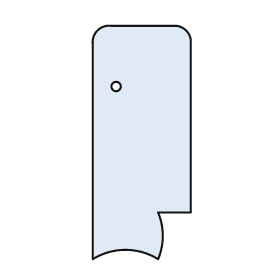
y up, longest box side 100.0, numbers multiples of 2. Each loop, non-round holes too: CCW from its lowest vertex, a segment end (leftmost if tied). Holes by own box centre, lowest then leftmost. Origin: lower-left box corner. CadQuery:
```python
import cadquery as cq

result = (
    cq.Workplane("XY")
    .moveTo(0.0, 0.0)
    .threePointArc((14.0, 4.0), (28.0, 0.0))
    .threePointArc((30.0, 10.0), (28.0, 20.0))
    .lineTo(42.0, 20.0)
    .lineTo(42.0, 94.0)
    .threePointArc((40.0, 98.0), (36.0, 100.0))
    .lineTo(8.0, 100.0)
    .threePointArc((2.0, 98.0), (0.0, 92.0))
    .close()
    .moveTo(10.0, 74.0)
    .circle(2.0)
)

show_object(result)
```